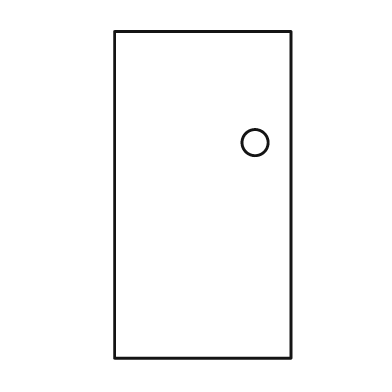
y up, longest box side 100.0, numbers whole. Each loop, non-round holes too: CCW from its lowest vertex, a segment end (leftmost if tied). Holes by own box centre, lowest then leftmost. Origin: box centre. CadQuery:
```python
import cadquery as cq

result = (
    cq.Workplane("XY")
    .moveTo(-27.0, -50.0)
    .lineTo(27.0, -50.0)
    .lineTo(27.0, 50.0)
    .lineTo(-27.0, 50.0)
    .close()
    .moveTo(16.0, 16.0)
    .circle(4.0)
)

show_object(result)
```